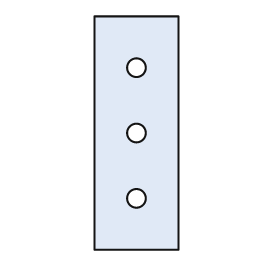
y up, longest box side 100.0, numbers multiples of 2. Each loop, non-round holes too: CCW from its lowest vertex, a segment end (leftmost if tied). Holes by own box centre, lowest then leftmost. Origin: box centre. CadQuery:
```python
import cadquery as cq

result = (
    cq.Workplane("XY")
    .moveTo(-18.0, -50.0)
    .lineTo(18.0, -50.0)
    .lineTo(18.0, 50.0)
    .lineTo(-18.0, 50.0)
    .close()
    .moveTo(0.0, -28.0)
    .circle(4.0)
    .moveTo(0.0, 0.0)
    .circle(4.0)
    .moveTo(0.0, 28.0)
    .circle(4.0)
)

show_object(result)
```